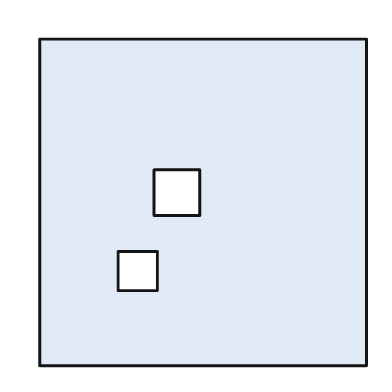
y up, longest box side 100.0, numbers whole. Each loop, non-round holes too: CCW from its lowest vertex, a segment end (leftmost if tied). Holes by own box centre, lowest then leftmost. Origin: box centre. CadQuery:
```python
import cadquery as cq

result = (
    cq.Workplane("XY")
    .moveTo(-50.0, -50.0)
    .lineTo(50.0, -50.0)
    .lineTo(50.0, 50.0)
    .lineTo(-50.0, 50.0)
    .close()
    .moveTo(-26.0, -27.0)
    .lineTo(-14.0, -27.0)
    .lineTo(-14.0, -15.0)
    .lineTo(-26.0, -15.0)
    .close()
    .moveTo(-15.0, -4.0)
    .lineTo(-1.0, -4.0)
    .lineTo(-1.0, 10.0)
    .lineTo(-15.0, 10.0)
    .close()
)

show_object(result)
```